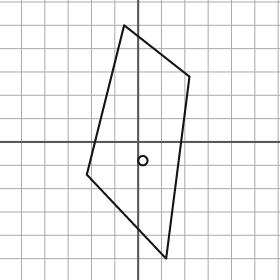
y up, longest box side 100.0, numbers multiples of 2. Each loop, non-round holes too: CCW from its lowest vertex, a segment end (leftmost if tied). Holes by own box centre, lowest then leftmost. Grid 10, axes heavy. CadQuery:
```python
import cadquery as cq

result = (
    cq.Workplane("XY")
    .moveTo(12.0, -50.0)
    .lineTo(22.0, 28.0)
    .lineTo(-6.0, 50.0)
    .lineTo(-22.0, -14.0)
    .close()
    .moveTo(2.0, -8.0)
    .circle(2.0)
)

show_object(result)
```